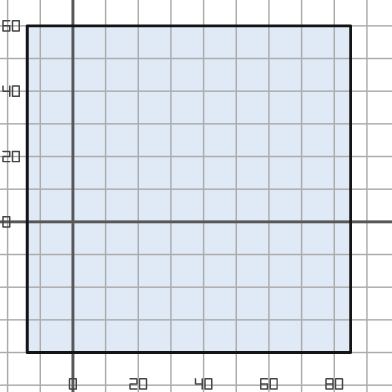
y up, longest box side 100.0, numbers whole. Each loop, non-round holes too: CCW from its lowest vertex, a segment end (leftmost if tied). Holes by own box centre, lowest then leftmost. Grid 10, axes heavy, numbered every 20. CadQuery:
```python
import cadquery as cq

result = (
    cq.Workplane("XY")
    .moveTo(-14.0, -40.0)
    .lineTo(85.0, -40.0)
    .lineTo(85.0, 60.0)
    .lineTo(-14.0, 60.0)
    .close()
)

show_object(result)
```